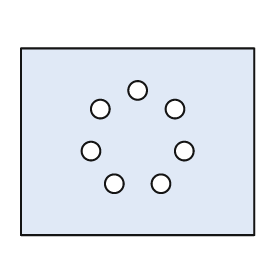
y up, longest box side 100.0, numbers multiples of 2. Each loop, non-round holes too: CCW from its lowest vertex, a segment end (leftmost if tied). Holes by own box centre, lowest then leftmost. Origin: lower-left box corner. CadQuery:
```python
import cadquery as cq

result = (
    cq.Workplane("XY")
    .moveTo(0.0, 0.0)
    .lineTo(100.0, 0.0)
    .lineTo(100.0, 80.0)
    .lineTo(0.0, 80.0)
    .close()
    .moveTo(40.0, 22.0)
    .circle(4.0)
    .moveTo(60.0, 22.0)
    .circle(4.0)
    .moveTo(30.0, 36.0)
    .circle(4.0)
    .moveTo(70.0, 36.0)
    .circle(4.0)
    .moveTo(34.0, 54.0)
    .circle(4.0)
    .moveTo(66.0, 54.0)
    .circle(4.0)
    .moveTo(50.0, 62.0)
    .circle(4.0)
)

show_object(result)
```